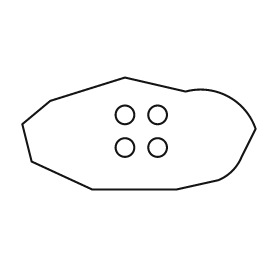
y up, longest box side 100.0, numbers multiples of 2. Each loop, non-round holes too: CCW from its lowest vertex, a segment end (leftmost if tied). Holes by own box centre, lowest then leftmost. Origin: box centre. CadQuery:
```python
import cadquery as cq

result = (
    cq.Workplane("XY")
    .moveTo(-20.0, -24.0)
    .lineTo(16.0, -24.0)
    .lineTo(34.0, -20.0)
    .threePointArc((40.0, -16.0), (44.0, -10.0))
    .lineTo(50.0, 2.0)
    .threePointArc((38.0, 16.0), (20.0, 18.0))
    .lineTo(-6.0, 24.0)
    .lineTo(-38.0, 14.0)
    .lineTo(-50.0, 4.0)
    .lineTo(-46.0, -12.0)
    .close()
    .moveTo(-6.0, -6.0)
    .circle(4.0)
    .moveTo(8.0, -6.0)
    .circle(4.0)
    .moveTo(-6.0, 8.0)
    .circle(4.0)
    .moveTo(8.0, 8.0)
    .circle(4.0)
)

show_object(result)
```